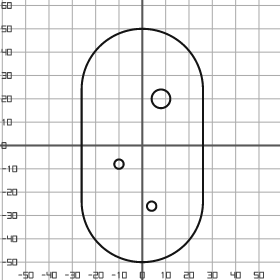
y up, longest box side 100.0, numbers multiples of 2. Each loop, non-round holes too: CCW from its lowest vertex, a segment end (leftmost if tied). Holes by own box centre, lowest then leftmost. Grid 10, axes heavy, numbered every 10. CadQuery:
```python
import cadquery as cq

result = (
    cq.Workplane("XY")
    .moveTo(-26.0, -24.0)
    .threePointArc((0.0, -50.0), (26.0, -24.0))
    .lineTo(26.0, 24.0)
    .threePointArc((0.0, 50.0), (-26.0, 24.0))
    .close()
    .moveTo(4.0, -26.0)
    .circle(2.0)
    .moveTo(-10.0, -8.0)
    .circle(2.0)
    .moveTo(8.0, 20.0)
    .circle(4.0)
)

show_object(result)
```